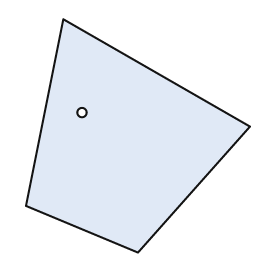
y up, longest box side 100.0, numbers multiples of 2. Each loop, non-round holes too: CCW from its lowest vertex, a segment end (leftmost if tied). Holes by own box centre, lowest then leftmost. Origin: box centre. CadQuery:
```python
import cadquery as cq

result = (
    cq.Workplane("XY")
    .moveTo(0.0, -50.0)
    .lineTo(48.0, 4.0)
    .lineTo(-32.0, 50.0)
    .lineTo(-48.0, -30.0)
    .close()
    .moveTo(-24.0, 10.0)
    .circle(2.0)
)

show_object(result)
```